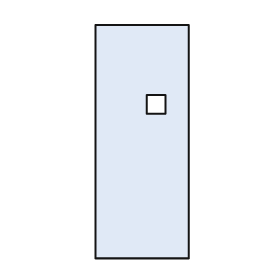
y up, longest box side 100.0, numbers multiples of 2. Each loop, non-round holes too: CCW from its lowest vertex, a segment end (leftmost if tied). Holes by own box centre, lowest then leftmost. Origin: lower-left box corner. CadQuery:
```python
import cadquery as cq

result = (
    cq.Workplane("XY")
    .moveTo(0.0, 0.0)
    .lineTo(40.0, 0.0)
    .lineTo(40.0, 100.0)
    .lineTo(0.0, 100.0)
    .close()
    .moveTo(22.0, 62.0)
    .lineTo(30.0, 62.0)
    .lineTo(30.0, 70.0)
    .lineTo(22.0, 70.0)
    .close()
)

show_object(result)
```